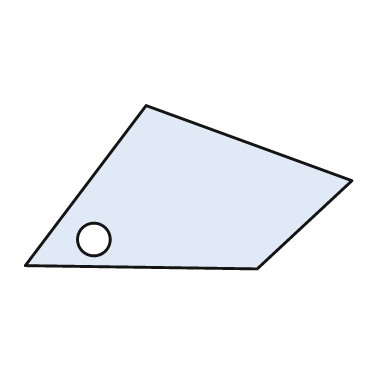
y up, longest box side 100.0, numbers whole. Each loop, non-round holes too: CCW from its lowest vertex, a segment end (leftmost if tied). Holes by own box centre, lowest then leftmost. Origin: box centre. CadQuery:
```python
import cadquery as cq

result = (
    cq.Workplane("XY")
    .moveTo(21.0, -25.0)
    .lineTo(50.0, 2.0)
    .lineTo(-13.0, 25.0)
    .lineTo(-50.0, -24.0)
    .close()
    .moveTo(-29.0, -16.0)
    .circle(5.0)
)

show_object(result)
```